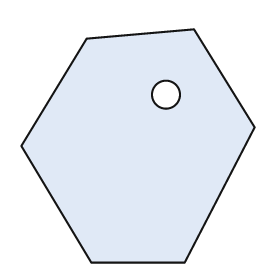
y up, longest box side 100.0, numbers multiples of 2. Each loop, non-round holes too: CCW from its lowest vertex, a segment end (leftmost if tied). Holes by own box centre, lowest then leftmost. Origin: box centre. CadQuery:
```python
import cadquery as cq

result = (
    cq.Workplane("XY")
    .moveTo(-20.0, -50.0)
    .lineTo(20.0, -50.0)
    .lineTo(50.0, 8.0)
    .lineTo(24.0, 50.0)
    .lineTo(-22.0, 46.0)
    .lineTo(-50.0, 0.0)
    .close()
    .moveTo(12.0, 22.0)
    .circle(6.0)
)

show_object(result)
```